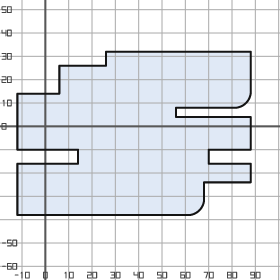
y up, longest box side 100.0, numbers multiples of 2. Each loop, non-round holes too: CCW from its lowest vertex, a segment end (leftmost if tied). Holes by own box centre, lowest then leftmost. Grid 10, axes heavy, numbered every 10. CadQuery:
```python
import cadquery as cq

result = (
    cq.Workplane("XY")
    .moveTo(-12.0, -38.0)
    .lineTo(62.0, -38.0)
    .threePointArc((66.0, -36.0), (68.0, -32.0))
    .lineTo(68.0, -24.0)
    .lineTo(88.0, -24.0)
    .lineTo(88.0, -16.0)
    .lineTo(70.0, -16.0)
    .lineTo(70.0, -10.0)
    .lineTo(88.0, -10.0)
    .lineTo(88.0, 4.0)
    .lineTo(56.0, 4.0)
    .lineTo(56.0, 8.0)
    .lineTo(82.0, 8.0)
    .threePointArc((86.0, 10.0), (88.0, 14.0))
    .lineTo(88.0, 32.0)
    .lineTo(26.0, 32.0)
    .lineTo(26.0, 26.0)
    .lineTo(6.0, 26.0)
    .lineTo(6.0, 14.0)
    .lineTo(-12.0, 14.0)
    .lineTo(-12.0, -10.0)
    .lineTo(14.0, -10.0)
    .lineTo(14.0, -16.0)
    .lineTo(-12.0, -16.0)
    .close()
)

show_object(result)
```